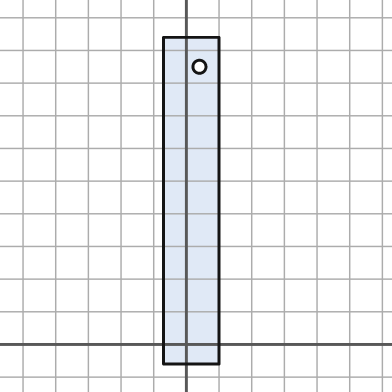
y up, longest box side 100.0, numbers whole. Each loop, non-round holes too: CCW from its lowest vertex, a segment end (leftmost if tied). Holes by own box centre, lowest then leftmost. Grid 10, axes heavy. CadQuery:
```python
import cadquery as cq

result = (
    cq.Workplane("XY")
    .moveTo(-7.0, -6.0)
    .lineTo(10.0, -6.0)
    .lineTo(10.0, 94.0)
    .lineTo(-7.0, 94.0)
    .close()
    .moveTo(4.0, 85.0)
    .circle(2.0)
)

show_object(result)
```